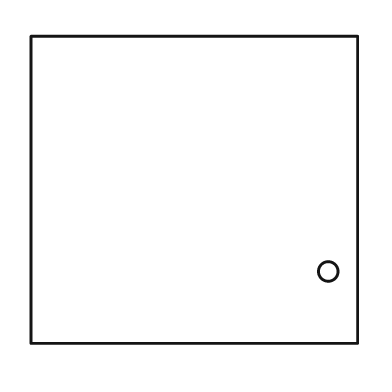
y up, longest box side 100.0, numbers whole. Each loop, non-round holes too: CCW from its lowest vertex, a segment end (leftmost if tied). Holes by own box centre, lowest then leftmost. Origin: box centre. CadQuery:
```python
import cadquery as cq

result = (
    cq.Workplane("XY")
    .moveTo(-50.0, -47.0)
    .lineTo(50.0, -47.0)
    .lineTo(50.0, 47.0)
    .lineTo(-50.0, 47.0)
    .close()
    .moveTo(41.0, -25.0)
    .circle(3.0)
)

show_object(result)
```